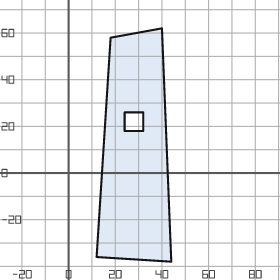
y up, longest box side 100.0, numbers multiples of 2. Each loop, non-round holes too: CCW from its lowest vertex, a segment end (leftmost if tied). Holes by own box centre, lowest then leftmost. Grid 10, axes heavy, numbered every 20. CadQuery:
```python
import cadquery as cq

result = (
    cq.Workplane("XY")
    .moveTo(44.0, -38.0)
    .lineTo(40.0, 62.0)
    .lineTo(18.0, 58.0)
    .lineTo(12.0, -36.0)
    .close()
    .moveTo(24.0, 18.0)
    .lineTo(32.0, 18.0)
    .lineTo(32.0, 26.0)
    .lineTo(24.0, 26.0)
    .close()
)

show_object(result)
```